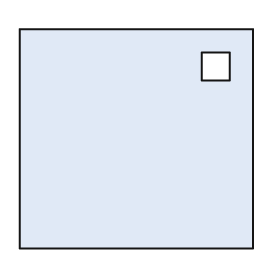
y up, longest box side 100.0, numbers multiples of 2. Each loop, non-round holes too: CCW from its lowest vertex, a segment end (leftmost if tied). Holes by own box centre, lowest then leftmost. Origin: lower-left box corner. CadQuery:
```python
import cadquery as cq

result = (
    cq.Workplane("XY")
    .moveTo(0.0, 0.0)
    .lineTo(100.0, 0.0)
    .lineTo(100.0, 94.0)
    .lineTo(0.0, 94.0)
    .close()
    .moveTo(78.0, 72.0)
    .lineTo(90.0, 72.0)
    .lineTo(90.0, 84.0)
    .lineTo(78.0, 84.0)
    .close()
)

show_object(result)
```